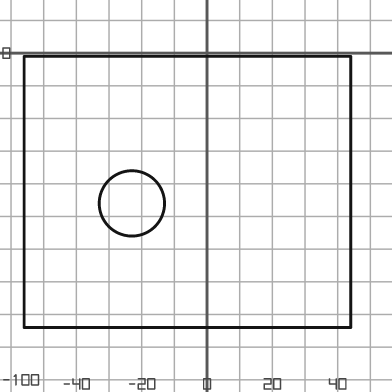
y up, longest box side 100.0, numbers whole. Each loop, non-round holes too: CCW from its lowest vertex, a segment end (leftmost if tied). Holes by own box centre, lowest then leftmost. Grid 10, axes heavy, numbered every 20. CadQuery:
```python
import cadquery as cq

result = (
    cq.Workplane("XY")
    .moveTo(-56.0, -84.0)
    .lineTo(44.0, -84.0)
    .lineTo(44.0, -1.0)
    .lineTo(-56.0, -1.0)
    .close()
    .moveTo(-23.0, -46.0)
    .circle(10.0)
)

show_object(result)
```